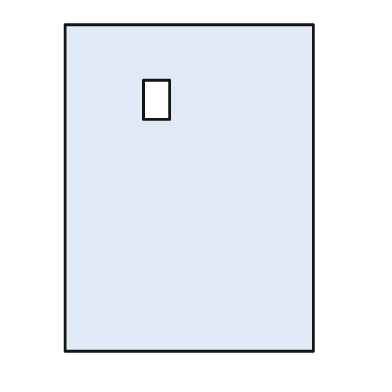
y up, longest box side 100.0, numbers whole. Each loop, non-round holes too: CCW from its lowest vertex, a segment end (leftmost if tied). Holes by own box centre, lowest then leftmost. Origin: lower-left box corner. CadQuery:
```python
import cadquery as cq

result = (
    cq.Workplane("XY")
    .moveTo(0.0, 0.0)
    .lineTo(76.0, 0.0)
    .lineTo(76.0, 100.0)
    .lineTo(0.0, 100.0)
    .close()
    .moveTo(24.0, 71.0)
    .lineTo(32.0, 71.0)
    .lineTo(32.0, 83.0)
    .lineTo(24.0, 83.0)
    .close()
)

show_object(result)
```